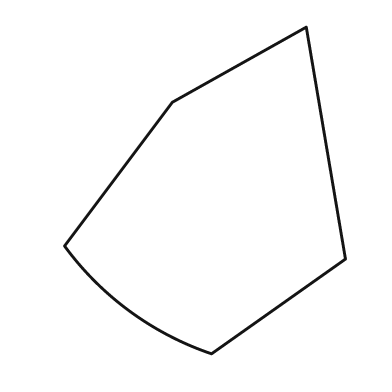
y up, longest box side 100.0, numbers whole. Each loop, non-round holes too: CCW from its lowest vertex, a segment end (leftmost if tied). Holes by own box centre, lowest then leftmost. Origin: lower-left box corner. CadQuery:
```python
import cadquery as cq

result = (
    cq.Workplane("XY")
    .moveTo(45.0, 0.0)
    .lineTo(86.0, 29.0)
    .lineTo(74.0, 100.0)
    .lineTo(33.0, 77.0)
    .lineTo(0.0, 33.0)
    .threePointArc((20.0, 13.0), (45.0, 0.0))
    .close()
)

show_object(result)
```